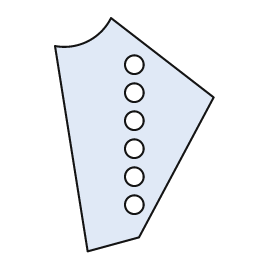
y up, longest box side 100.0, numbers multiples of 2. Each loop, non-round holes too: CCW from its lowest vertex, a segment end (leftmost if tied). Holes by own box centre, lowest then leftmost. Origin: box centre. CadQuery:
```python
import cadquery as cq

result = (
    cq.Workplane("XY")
    .moveTo(-20.0, -50.0)
    .lineTo(2.0, -44.0)
    .lineTo(34.0, 16.0)
    .lineTo(-10.0, 50.0)
    .threePointArc((-20.0, 40.0), (-34.0, 38.0))
    .close()
    .moveTo(0.0, -30.0)
    .circle(4.0)
    .moveTo(0.0, -18.0)
    .circle(4.0)
    .moveTo(0.0, -6.0)
    .circle(4.0)
    .moveTo(0.0, 6.0)
    .circle(4.0)
    .moveTo(0.0, 18.0)
    .circle(4.0)
    .moveTo(0.0, 30.0)
    .circle(4.0)
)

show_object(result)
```